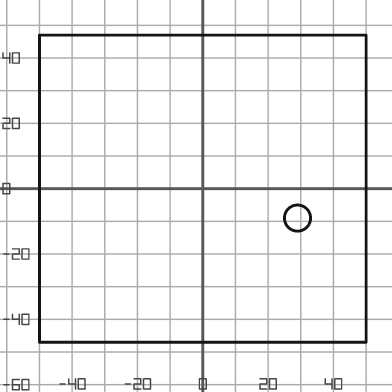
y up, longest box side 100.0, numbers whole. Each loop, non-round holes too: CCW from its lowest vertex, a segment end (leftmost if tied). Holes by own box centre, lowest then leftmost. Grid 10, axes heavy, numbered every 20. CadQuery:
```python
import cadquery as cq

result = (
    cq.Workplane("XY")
    .moveTo(-50.0, -47.0)
    .lineTo(50.0, -47.0)
    .lineTo(50.0, 47.0)
    .lineTo(-50.0, 47.0)
    .close()
    .moveTo(29.0, -9.0)
    .circle(4.0)
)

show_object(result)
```